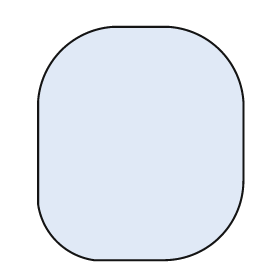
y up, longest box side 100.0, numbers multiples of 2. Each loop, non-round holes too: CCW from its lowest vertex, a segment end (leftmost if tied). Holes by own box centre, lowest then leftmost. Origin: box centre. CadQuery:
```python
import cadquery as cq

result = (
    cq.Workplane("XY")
    .moveTo(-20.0, -50.0)
    .lineTo(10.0, -50.0)
    .threePointArc((34.0, -40.0), (44.0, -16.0))
    .lineTo(44.0, 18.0)
    .threePointArc((34.0, 40.0), (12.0, 50.0))
    .lineTo(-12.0, 50.0)
    .threePointArc((-34.0, 40.0), (-44.0, 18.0))
    .lineTo(-44.0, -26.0)
    .threePointArc((-36.0, -42.0), (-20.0, -50.0))
    .close()
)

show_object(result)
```